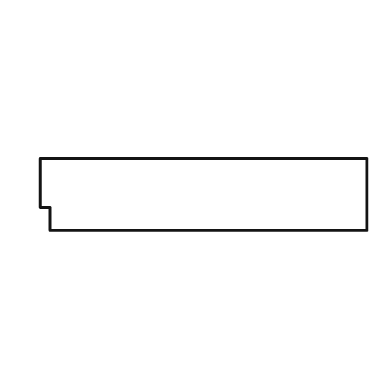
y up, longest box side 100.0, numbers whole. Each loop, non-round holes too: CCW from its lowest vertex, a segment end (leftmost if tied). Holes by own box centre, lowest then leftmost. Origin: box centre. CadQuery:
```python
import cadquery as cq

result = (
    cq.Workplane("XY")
    .moveTo(-47.0, -11.0)
    .lineTo(50.0, -11.0)
    .lineTo(50.0, 11.0)
    .lineTo(-50.0, 11.0)
    .lineTo(-50.0, -4.0)
    .lineTo(-47.0, -4.0)
    .close()
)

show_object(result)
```